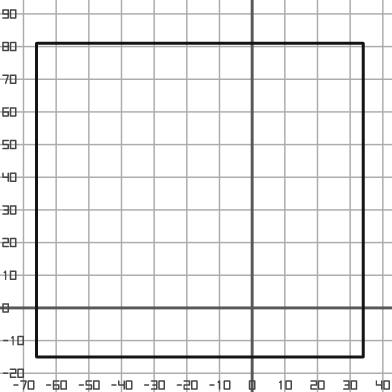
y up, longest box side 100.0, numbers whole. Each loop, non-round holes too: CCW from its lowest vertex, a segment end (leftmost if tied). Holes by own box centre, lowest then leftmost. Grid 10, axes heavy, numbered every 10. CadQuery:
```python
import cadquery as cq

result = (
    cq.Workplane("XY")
    .moveTo(-66.0, -15.0)
    .lineTo(34.0, -15.0)
    .lineTo(34.0, 81.0)
    .lineTo(-66.0, 81.0)
    .close()
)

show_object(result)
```